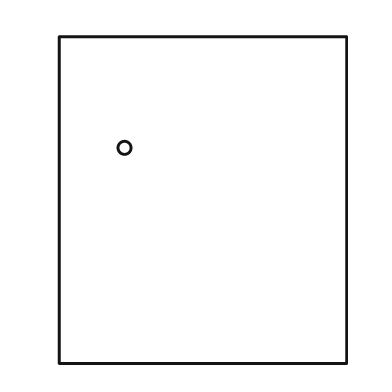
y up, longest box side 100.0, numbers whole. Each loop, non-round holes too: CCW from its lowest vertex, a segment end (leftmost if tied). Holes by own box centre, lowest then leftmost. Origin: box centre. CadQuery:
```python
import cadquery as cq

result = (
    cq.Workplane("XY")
    .moveTo(-44.0, -50.0)
    .lineTo(44.0, -50.0)
    .lineTo(44.0, 50.0)
    .lineTo(-44.0, 50.0)
    .close()
    .moveTo(-24.0, 16.0)
    .circle(2.0)
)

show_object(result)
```